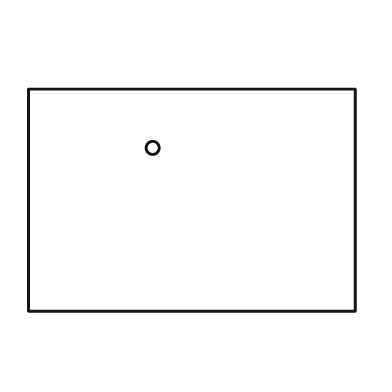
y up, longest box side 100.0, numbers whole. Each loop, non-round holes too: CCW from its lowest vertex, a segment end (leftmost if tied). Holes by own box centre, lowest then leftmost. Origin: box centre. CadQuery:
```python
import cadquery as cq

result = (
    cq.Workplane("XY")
    .moveTo(-50.0, -34.0)
    .lineTo(50.0, -34.0)
    .lineTo(50.0, 34.0)
    .lineTo(-50.0, 34.0)
    .close()
    .moveTo(-12.0, 16.0)
    .circle(2.0)
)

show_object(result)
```